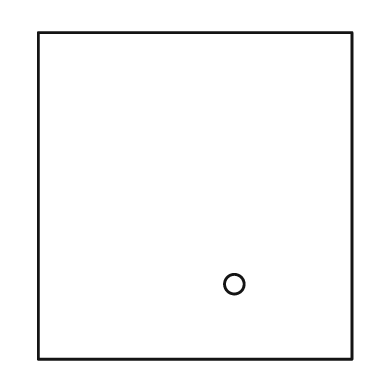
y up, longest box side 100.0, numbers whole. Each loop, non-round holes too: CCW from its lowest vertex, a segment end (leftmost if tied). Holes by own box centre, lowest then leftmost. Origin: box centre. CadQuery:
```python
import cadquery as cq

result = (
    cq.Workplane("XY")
    .moveTo(-48.0, -50.0)
    .lineTo(48.0, -50.0)
    .lineTo(48.0, 50.0)
    .lineTo(-48.0, 50.0)
    .close()
    .moveTo(12.0, -27.0)
    .circle(3.0)
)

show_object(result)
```